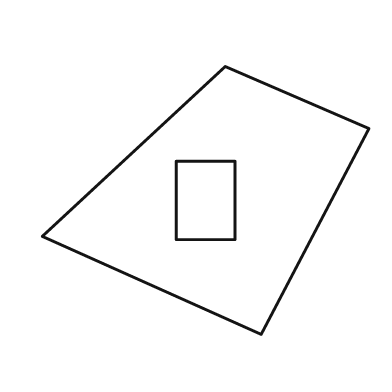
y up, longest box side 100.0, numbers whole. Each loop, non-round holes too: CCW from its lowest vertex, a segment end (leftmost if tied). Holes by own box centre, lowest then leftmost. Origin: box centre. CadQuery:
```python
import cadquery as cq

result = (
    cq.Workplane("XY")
    .moveTo(17.0, -41.0)
    .lineTo(50.0, 22.0)
    .lineTo(6.0, 41.0)
    .lineTo(-50.0, -11.0)
    .close()
    .moveTo(-9.0, -12.0)
    .lineTo(9.0, -12.0)
    .lineTo(9.0, 12.0)
    .lineTo(-9.0, 12.0)
    .close()
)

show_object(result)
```